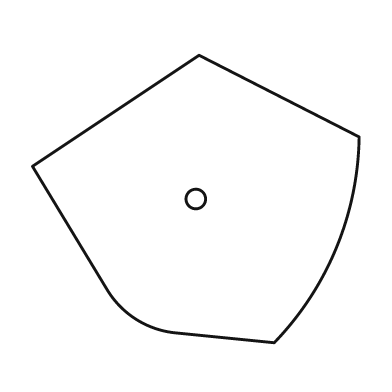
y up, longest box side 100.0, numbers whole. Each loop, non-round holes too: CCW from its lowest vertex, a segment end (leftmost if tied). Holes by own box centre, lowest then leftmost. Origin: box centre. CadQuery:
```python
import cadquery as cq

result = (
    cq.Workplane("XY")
    .moveTo(24.0, -44.0)
    .threePointArc((43.0, -15.0), (50.0, 19.0))
    .lineTo(1.0, 44.0)
    .lineTo(-50.0, 10.0)
    .lineTo(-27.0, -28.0)
    .threePointArc((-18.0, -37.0), (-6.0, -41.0))
    .close()
    .moveTo(0.0, 0.0)
    .circle(3.0)
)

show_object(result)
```